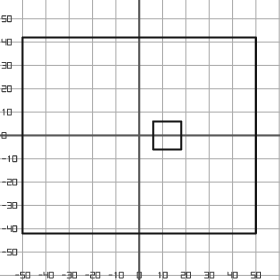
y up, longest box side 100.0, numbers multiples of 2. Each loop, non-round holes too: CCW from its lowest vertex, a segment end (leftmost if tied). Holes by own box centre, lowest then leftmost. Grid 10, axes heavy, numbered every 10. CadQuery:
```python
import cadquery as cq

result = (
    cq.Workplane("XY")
    .moveTo(-50.0, -42.0)
    .lineTo(50.0, -42.0)
    .lineTo(50.0, 42.0)
    .lineTo(-50.0, 42.0)
    .close()
    .moveTo(6.0, -6.0)
    .lineTo(18.0, -6.0)
    .lineTo(18.0, 6.0)
    .lineTo(6.0, 6.0)
    .close()
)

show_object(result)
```